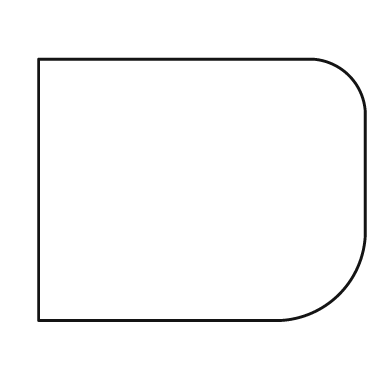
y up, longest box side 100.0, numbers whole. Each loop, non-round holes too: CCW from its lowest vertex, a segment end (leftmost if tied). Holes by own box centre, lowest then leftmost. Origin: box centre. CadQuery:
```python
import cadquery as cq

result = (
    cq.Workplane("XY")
    .moveTo(-50.0, -40.0)
    .lineTo(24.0, -40.0)
    .threePointArc((42.0, -32.0), (50.0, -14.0))
    .lineTo(50.0, 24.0)
    .threePointArc((45.0, 35.0), (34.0, 40.0))
    .lineTo(-50.0, 40.0)
    .close()
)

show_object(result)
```